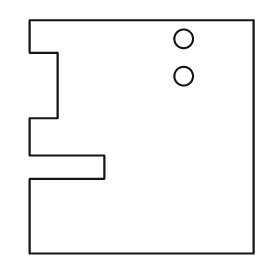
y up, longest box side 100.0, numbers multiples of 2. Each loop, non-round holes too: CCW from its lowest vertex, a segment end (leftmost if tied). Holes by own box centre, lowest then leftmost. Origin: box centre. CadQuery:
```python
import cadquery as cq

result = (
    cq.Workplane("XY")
    .moveTo(-48.0, -50.0)
    .lineTo(48.0, -50.0)
    .lineTo(48.0, 50.0)
    .lineTo(-48.0, 50.0)
    .lineTo(-48.0, 36.0)
    .lineTo(-36.0, 36.0)
    .lineTo(-36.0, 8.0)
    .lineTo(-48.0, 8.0)
    .lineTo(-48.0, -8.0)
    .lineTo(-16.0, -8.0)
    .lineTo(-16.0, -18.0)
    .lineTo(-48.0, -18.0)
    .close()
    .moveTo(18.0, 26.0)
    .circle(4.0)
    .moveTo(18.0, 42.0)
    .circle(4.0)
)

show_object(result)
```